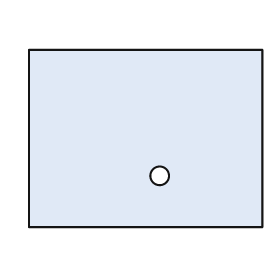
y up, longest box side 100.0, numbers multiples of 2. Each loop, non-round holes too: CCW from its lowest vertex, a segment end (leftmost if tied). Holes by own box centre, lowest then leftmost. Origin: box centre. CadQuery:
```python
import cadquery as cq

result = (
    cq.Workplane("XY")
    .moveTo(-50.0, -38.0)
    .lineTo(50.0, -38.0)
    .lineTo(50.0, 38.0)
    .lineTo(-50.0, 38.0)
    .close()
    .moveTo(6.0, -16.0)
    .circle(4.0)
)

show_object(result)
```